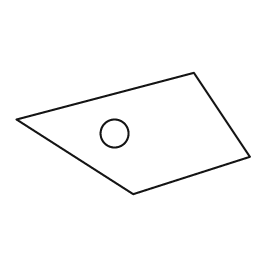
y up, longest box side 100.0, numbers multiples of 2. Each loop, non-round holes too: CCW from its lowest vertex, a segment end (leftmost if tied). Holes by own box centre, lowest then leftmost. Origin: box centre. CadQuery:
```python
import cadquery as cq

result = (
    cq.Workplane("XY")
    .moveTo(0.0, -26.0)
    .lineTo(50.0, -10.0)
    .lineTo(26.0, 26.0)
    .lineTo(-50.0, 6.0)
    .close()
    .moveTo(-8.0, 0.0)
    .circle(6.0)
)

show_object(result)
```